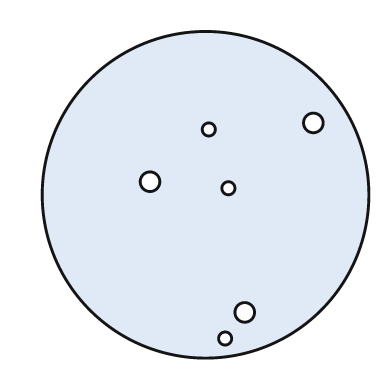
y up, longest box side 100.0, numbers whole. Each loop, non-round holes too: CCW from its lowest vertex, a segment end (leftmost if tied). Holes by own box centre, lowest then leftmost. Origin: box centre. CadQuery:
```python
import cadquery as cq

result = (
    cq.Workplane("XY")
    .moveTo(0.0, 0.0)
    .circle(50.0)
    .moveTo(6.0, -44.0)
    .circle(2.0)
    .moveTo(12.0, -36.0)
    .circle(3.0)
    .moveTo(7.0, 2.0)
    .circle(2.0)
    .moveTo(-17.0, 4.0)
    .circle(3.0)
    .moveTo(1.0, 20.0)
    .circle(2.0)
    .moveTo(33.0, 22.0)
    .circle(3.0)
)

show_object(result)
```